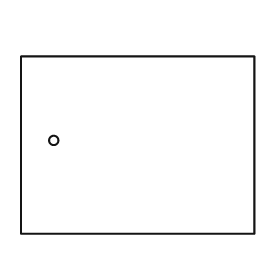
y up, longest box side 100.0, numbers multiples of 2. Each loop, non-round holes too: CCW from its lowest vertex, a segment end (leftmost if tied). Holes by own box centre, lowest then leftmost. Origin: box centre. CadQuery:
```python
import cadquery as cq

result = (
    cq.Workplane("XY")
    .moveTo(-50.0, -38.0)
    .lineTo(50.0, -38.0)
    .lineTo(50.0, 38.0)
    .lineTo(-50.0, 38.0)
    .close()
    .moveTo(-36.0, 2.0)
    .circle(2.0)
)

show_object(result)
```